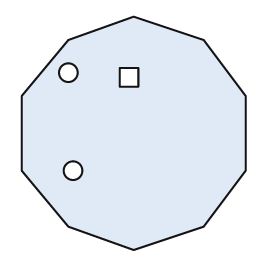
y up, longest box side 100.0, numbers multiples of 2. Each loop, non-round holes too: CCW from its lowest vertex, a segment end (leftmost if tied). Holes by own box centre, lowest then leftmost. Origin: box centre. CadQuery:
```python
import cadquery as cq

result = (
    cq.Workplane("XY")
    .moveTo(0.0, -50.0)
    .lineTo(30.0, -40.0)
    .lineTo(48.0, -16.0)
    .lineTo(48.0, 16.0)
    .lineTo(30.0, 40.0)
    .lineTo(0.0, 50.0)
    .lineTo(-28.0, 40.0)
    .lineTo(-48.0, 16.0)
    .lineTo(-48.0, -16.0)
    .lineTo(-28.0, -40.0)
    .close()
    .moveTo(-26.0, -16.0)
    .circle(4.0)
    .moveTo(-6.0, 20.0)
    .lineTo(2.0, 20.0)
    .lineTo(2.0, 28.0)
    .lineTo(-6.0, 28.0)
    .close()
    .moveTo(-28.0, 26.0)
    .circle(4.0)
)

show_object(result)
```